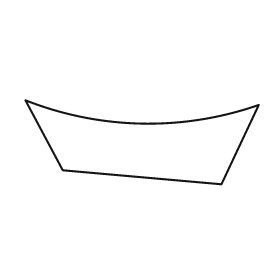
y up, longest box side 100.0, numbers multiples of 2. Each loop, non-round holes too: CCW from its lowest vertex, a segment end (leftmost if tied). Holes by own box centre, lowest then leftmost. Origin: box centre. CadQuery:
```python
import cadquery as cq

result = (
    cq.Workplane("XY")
    .moveTo(34.0, -18.0)
    .lineTo(50.0, 16.0)
    .threePointArc((0.0, 8.0), (-50.0, 18.0))
    .lineTo(-34.0, -12.0)
    .close()
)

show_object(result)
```